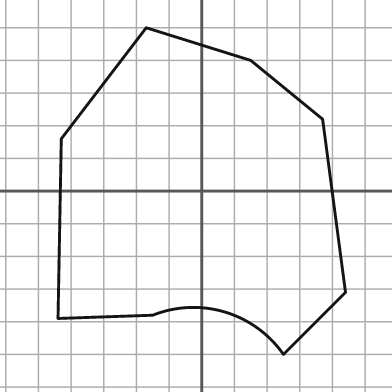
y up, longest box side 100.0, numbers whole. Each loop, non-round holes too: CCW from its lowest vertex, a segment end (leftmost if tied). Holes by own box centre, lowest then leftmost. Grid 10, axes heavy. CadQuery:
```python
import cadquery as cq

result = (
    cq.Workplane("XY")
    .moveTo(25.0, -50.0)
    .lineTo(44.0, -31.0)
    .lineTo(37.0, 22.0)
    .lineTo(15.0, 40.0)
    .lineTo(-17.0, 50.0)
    .lineTo(-43.0, 16.0)
    .lineTo(-44.0, -39.0)
    .lineTo(-15.0, -38.0)
    .threePointArc((7.0, -37.0), (25.0, -50.0))
    .close()
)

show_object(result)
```